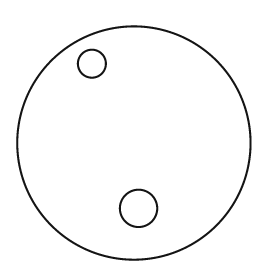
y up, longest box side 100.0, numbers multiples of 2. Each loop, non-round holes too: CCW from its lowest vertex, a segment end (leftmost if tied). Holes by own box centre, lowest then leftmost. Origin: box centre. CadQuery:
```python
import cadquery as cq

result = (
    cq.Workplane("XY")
    .moveTo(0.0, 0.0)
    .circle(50.0)
    .moveTo(2.0, -28.0)
    .circle(8.0)
    .moveTo(-18.0, 34.0)
    .circle(6.0)
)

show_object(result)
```